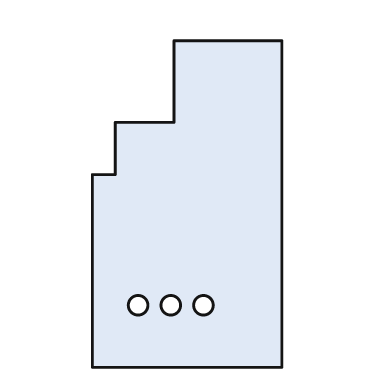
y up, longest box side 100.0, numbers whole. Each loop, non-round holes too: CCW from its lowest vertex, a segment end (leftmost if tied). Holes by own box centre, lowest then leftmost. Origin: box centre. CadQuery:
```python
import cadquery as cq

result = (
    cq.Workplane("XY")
    .moveTo(-29.0, -50.0)
    .lineTo(29.0, -50.0)
    .lineTo(29.0, 50.0)
    .lineTo(-4.0, 50.0)
    .lineTo(-4.0, 25.0)
    .lineTo(-22.0, 25.0)
    .lineTo(-22.0, 9.0)
    .lineTo(-29.0, 9.0)
    .close()
    .moveTo(-15.0, -31.0)
    .circle(3.0)
    .moveTo(-5.0, -31.0)
    .circle(3.0)
    .moveTo(5.0, -31.0)
    .circle(3.0)
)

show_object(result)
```